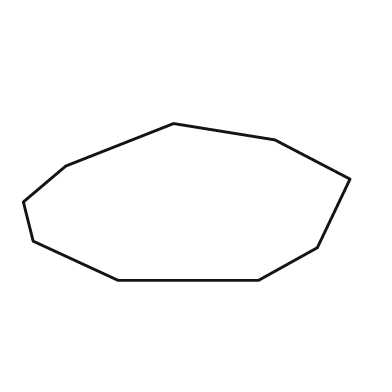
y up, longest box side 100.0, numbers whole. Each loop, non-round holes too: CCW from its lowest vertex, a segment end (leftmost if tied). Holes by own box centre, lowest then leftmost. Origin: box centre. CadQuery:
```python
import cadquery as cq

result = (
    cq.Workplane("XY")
    .moveTo(-21.0, -24.0)
    .lineTo(22.0, -24.0)
    .lineTo(40.0, -14.0)
    .lineTo(50.0, 7.0)
    .lineTo(27.0, 19.0)
    .lineTo(-4.0, 24.0)
    .lineTo(-37.0, 11.0)
    .lineTo(-50.0, 0.0)
    .lineTo(-47.0, -12.0)
    .close()
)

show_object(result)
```